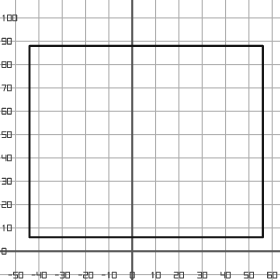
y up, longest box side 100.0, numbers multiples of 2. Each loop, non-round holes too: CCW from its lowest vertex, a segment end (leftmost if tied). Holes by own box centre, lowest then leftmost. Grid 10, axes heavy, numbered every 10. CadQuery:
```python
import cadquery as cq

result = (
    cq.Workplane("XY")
    .moveTo(-44.0, 6.0)
    .lineTo(56.0, 6.0)
    .lineTo(56.0, 88.0)
    .lineTo(-44.0, 88.0)
    .close()
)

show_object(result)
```